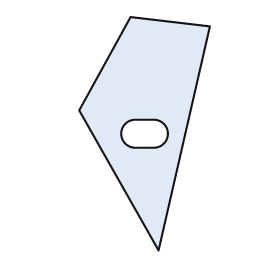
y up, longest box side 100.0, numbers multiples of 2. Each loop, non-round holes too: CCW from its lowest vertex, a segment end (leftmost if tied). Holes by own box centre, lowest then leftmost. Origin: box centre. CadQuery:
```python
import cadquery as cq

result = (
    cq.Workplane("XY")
    .moveTo(6.0, -50.0)
    .lineTo(28.0, 46.0)
    .lineTo(-6.0, 50.0)
    .lineTo(-28.0, 10.0)
    .close()
    .moveTo(-4.0, -6.0)
    .lineTo(4.0, -6.0)
    .threePointArc((10.0, 0.0), (4.0, 6.0))
    .lineTo(-4.0, 6.0)
    .threePointArc((-10.0, 0.0), (-4.0, -6.0))
    .close()
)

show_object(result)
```